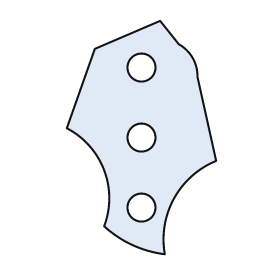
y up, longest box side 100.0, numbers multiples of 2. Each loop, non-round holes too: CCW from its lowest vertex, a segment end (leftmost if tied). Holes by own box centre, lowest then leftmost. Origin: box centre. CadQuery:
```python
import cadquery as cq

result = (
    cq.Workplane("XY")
    .moveTo(10.0, -50.0)
    .threePointArc((14.0, -26.0), (32.0, -10.0))
    .lineTo(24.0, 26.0)
    .threePointArc((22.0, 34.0), (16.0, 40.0))
    .lineTo(8.0, 50.0)
    .lineTo(-20.0, 38.0)
    .lineTo(-32.0, 4.0)
    .threePointArc((-16.0, -14.0), (-16.0, -38.0))
    .threePointArc((-4.0, -46.0), (10.0, -50.0))
    .close()
    .moveTo(0.0, -30.0)
    .circle(6.0)
    .moveTo(0.0, 0.0)
    .circle(6.0)
    .moveTo(0.0, 30.0)
    .circle(6.0)
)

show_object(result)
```